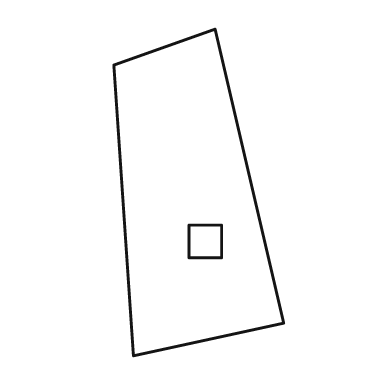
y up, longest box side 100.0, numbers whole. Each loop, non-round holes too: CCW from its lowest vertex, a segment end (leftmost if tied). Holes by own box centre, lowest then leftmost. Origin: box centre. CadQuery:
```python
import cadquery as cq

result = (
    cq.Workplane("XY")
    .moveTo(-20.0, -50.0)
    .lineTo(26.0, -40.0)
    .lineTo(5.0, 50.0)
    .lineTo(-26.0, 39.0)
    .close()
    .moveTo(-3.0, -20.0)
    .lineTo(7.0, -20.0)
    .lineTo(7.0, -10.0)
    .lineTo(-3.0, -10.0)
    .close()
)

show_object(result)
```